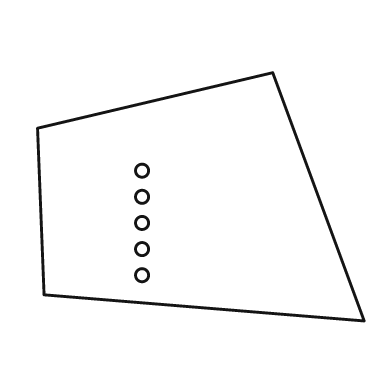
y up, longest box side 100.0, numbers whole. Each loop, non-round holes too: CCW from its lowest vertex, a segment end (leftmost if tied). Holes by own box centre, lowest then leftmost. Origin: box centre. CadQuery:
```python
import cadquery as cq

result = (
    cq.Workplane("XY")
    .moveTo(50.0, -38.0)
    .lineTo(22.0, 38.0)
    .lineTo(-50.0, 21.0)
    .lineTo(-48.0, -30.0)
    .close()
    .moveTo(-18.0, -24.0)
    .circle(2.0)
    .moveTo(-18.0, -16.0)
    .circle(2.0)
    .moveTo(-18.0, -8.0)
    .circle(2.0)
    .moveTo(-18.0, 0.0)
    .circle(2.0)
    .moveTo(-18.0, 8.0)
    .circle(2.0)
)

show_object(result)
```